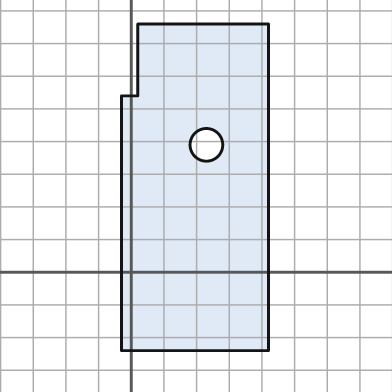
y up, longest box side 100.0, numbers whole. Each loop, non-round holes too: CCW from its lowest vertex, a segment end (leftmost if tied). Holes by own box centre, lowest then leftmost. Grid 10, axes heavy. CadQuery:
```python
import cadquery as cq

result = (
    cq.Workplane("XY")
    .moveTo(-3.0, -24.0)
    .lineTo(42.0, -24.0)
    .lineTo(42.0, 76.0)
    .lineTo(2.0, 76.0)
    .lineTo(2.0, 54.0)
    .lineTo(-3.0, 54.0)
    .close()
    .moveTo(23.0, 39.0)
    .circle(5.0)
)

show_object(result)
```